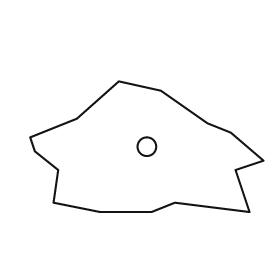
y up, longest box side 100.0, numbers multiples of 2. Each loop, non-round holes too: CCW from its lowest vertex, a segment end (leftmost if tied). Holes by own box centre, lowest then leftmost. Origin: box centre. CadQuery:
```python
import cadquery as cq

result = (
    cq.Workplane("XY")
    .moveTo(-20.0, -28.0)
    .lineTo(2.0, -28.0)
    .lineTo(12.0, -24.0)
    .lineTo(44.0, -28.0)
    .lineTo(38.0, -10.0)
    .lineTo(50.0, -6.0)
    .lineTo(36.0, 6.0)
    .lineTo(26.0, 10.0)
    .lineTo(6.0, 24.0)
    .lineTo(-12.0, 28.0)
    .lineTo(-30.0, 12.0)
    .lineTo(-50.0, 4.0)
    .lineTo(-48.0, -2.0)
    .lineTo(-38.0, -10.0)
    .lineTo(-40.0, -24.0)
    .close()
    .moveTo(0.0, 0.0)
    .circle(4.0)
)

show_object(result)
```